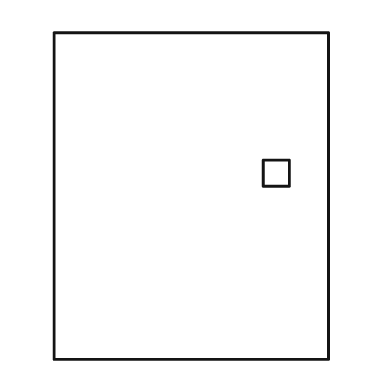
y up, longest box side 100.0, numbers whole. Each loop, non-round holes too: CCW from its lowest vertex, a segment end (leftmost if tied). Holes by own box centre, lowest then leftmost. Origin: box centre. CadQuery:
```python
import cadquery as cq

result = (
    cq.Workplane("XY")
    .moveTo(-42.0, -50.0)
    .lineTo(42.0, -50.0)
    .lineTo(42.0, 50.0)
    .lineTo(-42.0, 50.0)
    .close()
    .moveTo(22.0, 3.0)
    .lineTo(30.0, 3.0)
    .lineTo(30.0, 11.0)
    .lineTo(22.0, 11.0)
    .close()
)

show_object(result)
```